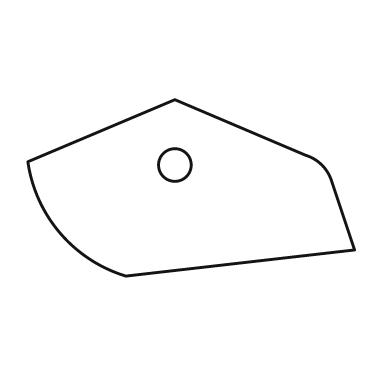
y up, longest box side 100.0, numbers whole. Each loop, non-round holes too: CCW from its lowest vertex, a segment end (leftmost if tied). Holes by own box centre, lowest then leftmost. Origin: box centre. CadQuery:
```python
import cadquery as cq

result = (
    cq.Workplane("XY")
    .moveTo(-20.0, -27.0)
    .lineTo(50.0, -19.0)
    .lineTo(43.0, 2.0)
    .threePointArc((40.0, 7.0), (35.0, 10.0))
    .lineTo(-5.0, 27.0)
    .lineTo(-50.0, 8.0)
    .threePointArc((-40.0, -14.0), (-20.0, -27.0))
    .close()
    .moveTo(-5.0, 7.0)
    .circle(5.0)
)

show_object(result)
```